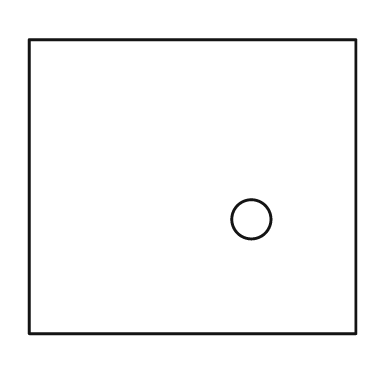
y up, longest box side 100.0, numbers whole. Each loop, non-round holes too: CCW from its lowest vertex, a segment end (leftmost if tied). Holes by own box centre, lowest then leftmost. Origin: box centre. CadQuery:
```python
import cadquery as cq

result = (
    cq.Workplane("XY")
    .moveTo(-50.0, -45.0)
    .lineTo(50.0, -45.0)
    .lineTo(50.0, 45.0)
    .lineTo(-50.0, 45.0)
    .close()
    .moveTo(18.0, -10.0)
    .circle(6.0)
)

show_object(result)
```